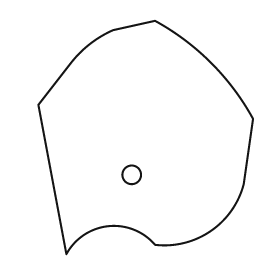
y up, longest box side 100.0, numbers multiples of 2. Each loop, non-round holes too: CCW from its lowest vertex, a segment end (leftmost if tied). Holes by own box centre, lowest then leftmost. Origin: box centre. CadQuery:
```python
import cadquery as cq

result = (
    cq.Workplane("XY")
    .moveTo(-34.0, -50.0)
    .threePointArc((-16.0, -38.0), (4.0, -46.0))
    .threePointArc((28.0, -40.0), (42.0, -20.0))
    .lineTo(46.0, 8.0)
    .threePointArc((28.0, 32.0), (4.0, 50.0))
    .lineTo(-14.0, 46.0)
    .threePointArc((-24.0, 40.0), (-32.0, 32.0))
    .lineTo(-46.0, 14.0)
    .close()
    .moveTo(-6.0, -16.0)
    .circle(4.0)
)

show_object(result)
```